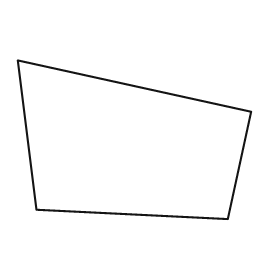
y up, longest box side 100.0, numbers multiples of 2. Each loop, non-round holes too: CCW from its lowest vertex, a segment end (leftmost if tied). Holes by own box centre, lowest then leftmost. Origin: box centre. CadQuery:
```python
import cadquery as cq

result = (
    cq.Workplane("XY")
    .moveTo(40.0, -34.0)
    .lineTo(50.0, 12.0)
    .lineTo(-50.0, 34.0)
    .lineTo(-42.0, -30.0)
    .close()
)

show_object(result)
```